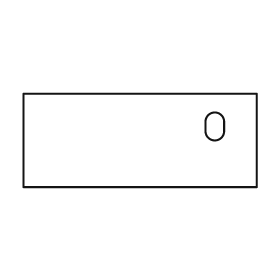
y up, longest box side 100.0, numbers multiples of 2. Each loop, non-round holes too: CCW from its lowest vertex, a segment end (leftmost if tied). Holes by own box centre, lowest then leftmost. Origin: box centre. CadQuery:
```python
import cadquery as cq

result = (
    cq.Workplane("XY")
    .moveTo(-50.0, -20.0)
    .lineTo(50.0, -20.0)
    .lineTo(50.0, 20.0)
    .lineTo(-50.0, 20.0)
    .close()
    .moveTo(28.0, 4.0)
    .threePointArc((32.0, 0.0), (36.0, 4.0))
    .lineTo(36.0, 8.0)
    .threePointArc((32.0, 12.0), (28.0, 8.0))
    .close()
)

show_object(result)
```